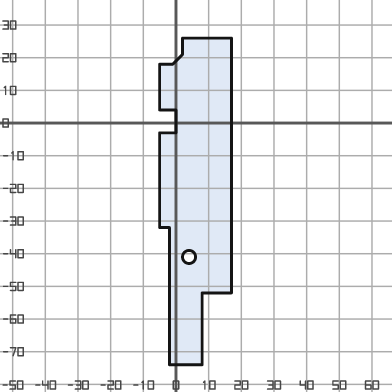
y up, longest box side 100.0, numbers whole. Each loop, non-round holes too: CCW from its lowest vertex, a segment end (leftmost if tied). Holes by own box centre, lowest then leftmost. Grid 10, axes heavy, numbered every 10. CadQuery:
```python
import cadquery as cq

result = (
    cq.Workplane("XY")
    .moveTo(-2.0, -74.0)
    .lineTo(8.0, -74.0)
    .lineTo(8.0, -52.0)
    .lineTo(17.0, -52.0)
    .lineTo(17.0, 26.0)
    .lineTo(2.0, 26.0)
    .lineTo(2.0, 21.0)
    .lineTo(-1.0, 18.0)
    .lineTo(-5.0, 18.0)
    .lineTo(-5.0, 4.0)
    .lineTo(0.0, 4.0)
    .lineTo(0.0, -3.0)
    .lineTo(-5.0, -3.0)
    .lineTo(-5.0, -32.0)
    .lineTo(-2.0, -32.0)
    .close()
    .moveTo(4.0, -41.0)
    .circle(2.0)
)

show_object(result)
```